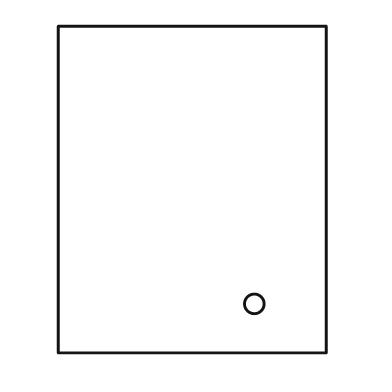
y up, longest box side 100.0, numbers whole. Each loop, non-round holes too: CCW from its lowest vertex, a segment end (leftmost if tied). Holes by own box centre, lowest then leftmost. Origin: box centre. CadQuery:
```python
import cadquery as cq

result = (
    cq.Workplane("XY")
    .moveTo(-41.0, -50.0)
    .lineTo(41.0, -50.0)
    .lineTo(41.0, 50.0)
    .lineTo(-41.0, 50.0)
    .close()
    .moveTo(19.0, -35.0)
    .circle(3.0)
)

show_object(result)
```